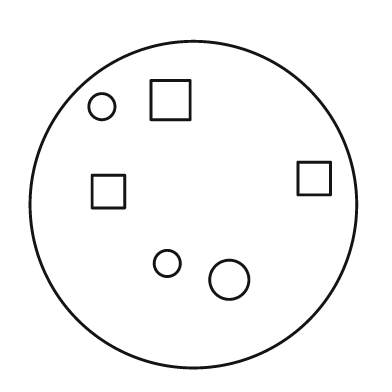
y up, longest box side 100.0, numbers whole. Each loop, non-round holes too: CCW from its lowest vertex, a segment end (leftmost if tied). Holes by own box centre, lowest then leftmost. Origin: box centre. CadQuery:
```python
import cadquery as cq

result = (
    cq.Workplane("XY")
    .moveTo(0.0, 0.0)
    .circle(50.0)
    .moveTo(11.0, -23.0)
    .circle(6.0)
    .moveTo(-8.0, -18.0)
    .circle(4.0)
    .moveTo(-31.0, -1.0)
    .lineTo(-21.0, -1.0)
    .lineTo(-21.0, 9.0)
    .lineTo(-31.0, 9.0)
    .close()
    .moveTo(32.0, 3.0)
    .lineTo(42.0, 3.0)
    .lineTo(42.0, 13.0)
    .lineTo(32.0, 13.0)
    .close()
    .moveTo(-28.0, 30.0)
    .circle(4.0)
    .moveTo(-13.0, 26.0)
    .lineTo(-1.0, 26.0)
    .lineTo(-1.0, 38.0)
    .lineTo(-13.0, 38.0)
    .close()
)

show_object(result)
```